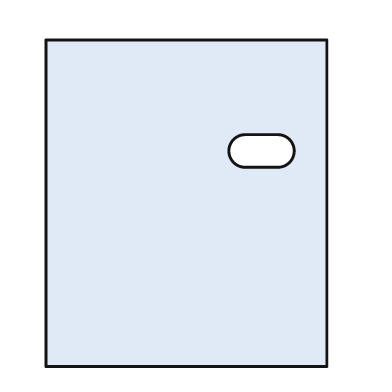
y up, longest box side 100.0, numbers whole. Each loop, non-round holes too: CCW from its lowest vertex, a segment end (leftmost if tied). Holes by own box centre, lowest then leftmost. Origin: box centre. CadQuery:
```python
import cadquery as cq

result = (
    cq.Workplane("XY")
    .moveTo(-43.0, -50.0)
    .lineTo(43.0, -50.0)
    .lineTo(43.0, 50.0)
    .lineTo(-43.0, 50.0)
    .close()
    .moveTo(18.0, 11.0)
    .lineTo(28.0, 11.0)
    .threePointArc((33.0, 16.0), (28.0, 21.0))
    .lineTo(18.0, 21.0)
    .threePointArc((13.0, 16.0), (18.0, 11.0))
    .close()
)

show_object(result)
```